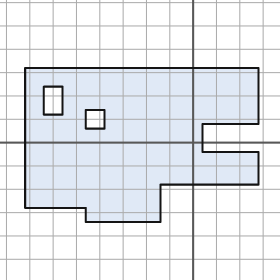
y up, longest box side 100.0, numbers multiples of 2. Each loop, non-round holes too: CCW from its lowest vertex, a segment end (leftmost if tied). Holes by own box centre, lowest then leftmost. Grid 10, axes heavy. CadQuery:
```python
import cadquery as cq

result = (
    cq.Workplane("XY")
    .moveTo(-46.0, -34.0)
    .lineTo(-14.0, -34.0)
    .lineTo(-14.0, -18.0)
    .lineTo(28.0, -18.0)
    .lineTo(28.0, -4.0)
    .lineTo(4.0, -4.0)
    .lineTo(4.0, 8.0)
    .lineTo(28.0, 8.0)
    .lineTo(28.0, 32.0)
    .lineTo(-72.0, 32.0)
    .lineTo(-72.0, -28.0)
    .lineTo(-46.0, -28.0)
    .close()
    .moveTo(-46.0, 6.0)
    .lineTo(-38.0, 6.0)
    .lineTo(-38.0, 14.0)
    .lineTo(-46.0, 14.0)
    .close()
    .moveTo(-64.0, 12.0)
    .lineTo(-56.0, 12.0)
    .lineTo(-56.0, 24.0)
    .lineTo(-64.0, 24.0)
    .close()
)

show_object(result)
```